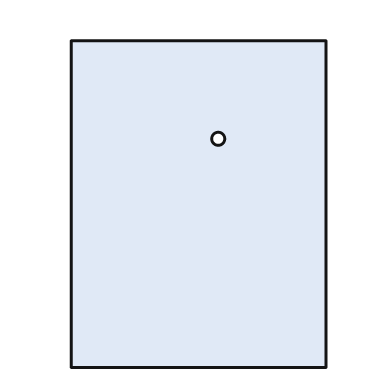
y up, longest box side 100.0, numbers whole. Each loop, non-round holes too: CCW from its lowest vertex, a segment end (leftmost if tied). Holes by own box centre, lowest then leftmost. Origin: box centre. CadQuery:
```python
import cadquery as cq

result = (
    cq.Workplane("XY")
    .moveTo(-39.0, -50.0)
    .lineTo(39.0, -50.0)
    .lineTo(39.0, 50.0)
    .lineTo(-39.0, 50.0)
    .close()
    .moveTo(6.0, 20.0)
    .circle(2.0)
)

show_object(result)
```